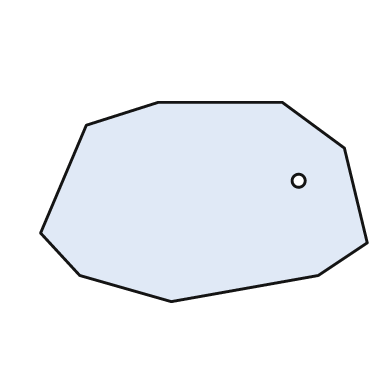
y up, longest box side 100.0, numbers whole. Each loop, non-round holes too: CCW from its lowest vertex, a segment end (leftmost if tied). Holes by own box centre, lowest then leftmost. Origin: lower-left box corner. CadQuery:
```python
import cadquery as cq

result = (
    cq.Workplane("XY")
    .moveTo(40.0, 0.0)
    .lineTo(85.0, 8.0)
    .lineTo(100.0, 18.0)
    .lineTo(93.0, 47.0)
    .lineTo(74.0, 61.0)
    .lineTo(36.0, 61.0)
    .lineTo(14.0, 54.0)
    .lineTo(0.0, 21.0)
    .lineTo(12.0, 8.0)
    .close()
    .moveTo(79.0, 37.0)
    .circle(2.0)
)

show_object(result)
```